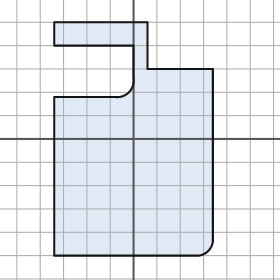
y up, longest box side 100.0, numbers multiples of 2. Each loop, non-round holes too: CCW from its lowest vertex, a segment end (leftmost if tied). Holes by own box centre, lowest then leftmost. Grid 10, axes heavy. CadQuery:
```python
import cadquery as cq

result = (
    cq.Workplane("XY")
    .moveTo(-34.0, -50.0)
    .lineTo(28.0, -50.0)
    .threePointArc((32.0, -48.0), (34.0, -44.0))
    .lineTo(34.0, 30.0)
    .lineTo(6.0, 30.0)
    .lineTo(6.0, 50.0)
    .lineTo(-34.0, 50.0)
    .lineTo(-34.0, 40.0)
    .lineTo(0.0, 40.0)
    .lineTo(0.0, 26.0)
    .threePointArc((-2.0, 20.0), (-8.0, 18.0))
    .lineTo(-34.0, 18.0)
    .close()
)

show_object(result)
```